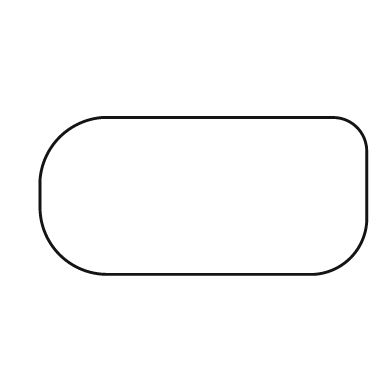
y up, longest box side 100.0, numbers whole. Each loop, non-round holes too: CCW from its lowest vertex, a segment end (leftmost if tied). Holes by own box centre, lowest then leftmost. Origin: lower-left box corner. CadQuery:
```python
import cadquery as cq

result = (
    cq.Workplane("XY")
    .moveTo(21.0, 0.0)
    .lineTo(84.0, 0.0)
    .threePointArc((95.0, 5.0), (100.0, 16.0))
    .lineTo(100.0, 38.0)
    .threePointArc((97.0, 45.0), (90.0, 48.0))
    .lineTo(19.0, 48.0)
    .threePointArc((6.0, 42.0), (0.0, 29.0))
    .lineTo(0.0, 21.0)
    .threePointArc((6.0, 6.0), (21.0, 0.0))
    .close()
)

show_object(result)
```